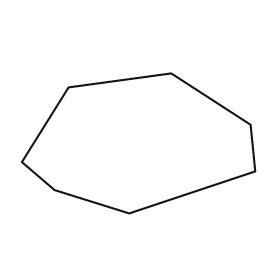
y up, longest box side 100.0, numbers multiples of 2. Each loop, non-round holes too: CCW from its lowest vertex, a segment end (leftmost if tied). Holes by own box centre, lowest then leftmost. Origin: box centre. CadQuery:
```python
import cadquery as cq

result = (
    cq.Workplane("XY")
    .moveTo(-4.0, -30.0)
    .lineTo(50.0, -12.0)
    .lineTo(48.0, 8.0)
    .lineTo(14.0, 30.0)
    .lineTo(-30.0, 24.0)
    .lineTo(-50.0, -8.0)
    .lineTo(-36.0, -20.0)
    .close()
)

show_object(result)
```